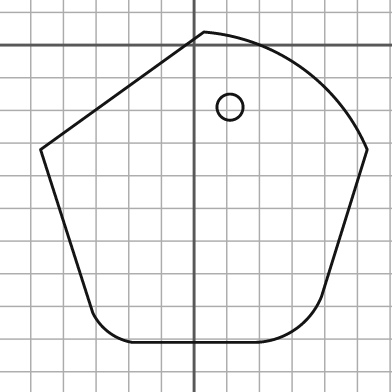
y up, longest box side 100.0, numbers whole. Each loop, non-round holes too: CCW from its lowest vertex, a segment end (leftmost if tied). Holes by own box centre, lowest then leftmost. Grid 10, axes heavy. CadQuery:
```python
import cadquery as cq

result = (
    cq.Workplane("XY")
    .moveTo(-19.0, -91.0)
    .lineTo(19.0, -91.0)
    .threePointArc((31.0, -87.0), (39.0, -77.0))
    .lineTo(53.0, -32.0)
    .threePointArc((33.0, -7.0), (3.0, 4.0))
    .lineTo(-47.0, -32.0)
    .lineTo(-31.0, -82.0)
    .threePointArc((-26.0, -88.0), (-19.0, -91.0))
    .close()
    .moveTo(11.0, -19.0)
    .circle(4.0)
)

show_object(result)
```